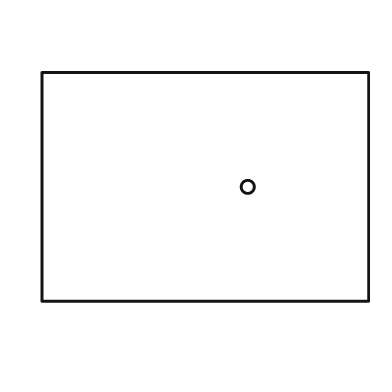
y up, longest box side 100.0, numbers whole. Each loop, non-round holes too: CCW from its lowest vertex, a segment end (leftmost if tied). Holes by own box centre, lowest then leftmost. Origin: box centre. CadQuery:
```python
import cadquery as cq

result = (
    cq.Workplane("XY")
    .moveTo(-50.0, -35.0)
    .lineTo(50.0, -35.0)
    .lineTo(50.0, 35.0)
    .lineTo(-50.0, 35.0)
    .close()
    .moveTo(13.0, 0.0)
    .circle(2.0)
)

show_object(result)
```